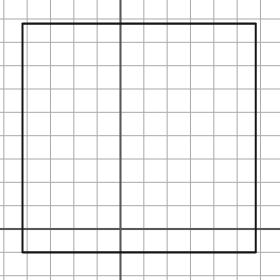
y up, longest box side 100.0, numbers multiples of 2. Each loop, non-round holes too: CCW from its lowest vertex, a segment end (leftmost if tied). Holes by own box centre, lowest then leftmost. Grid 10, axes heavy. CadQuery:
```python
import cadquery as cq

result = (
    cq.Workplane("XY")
    .moveTo(-42.0, -10.0)
    .lineTo(58.0, -10.0)
    .lineTo(58.0, 88.0)
    .lineTo(-42.0, 88.0)
    .close()
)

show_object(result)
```